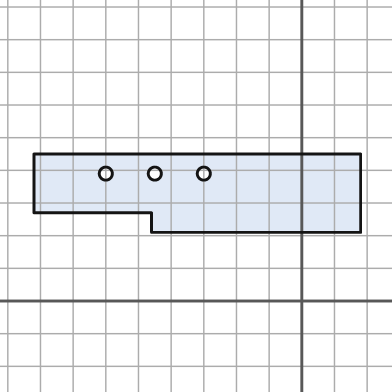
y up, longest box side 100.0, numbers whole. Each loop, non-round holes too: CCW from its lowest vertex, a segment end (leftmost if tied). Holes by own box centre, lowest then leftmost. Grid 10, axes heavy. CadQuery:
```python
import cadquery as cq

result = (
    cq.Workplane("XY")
    .moveTo(-46.0, 21.0)
    .lineTo(18.0, 21.0)
    .lineTo(18.0, 45.0)
    .lineTo(-82.0, 45.0)
    .lineTo(-82.0, 27.0)
    .lineTo(-46.0, 27.0)
    .close()
    .moveTo(-60.0, 39.0)
    .circle(2.0)
    .moveTo(-45.0, 39.0)
    .circle(2.0)
    .moveTo(-30.0, 39.0)
    .circle(2.0)
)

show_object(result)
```